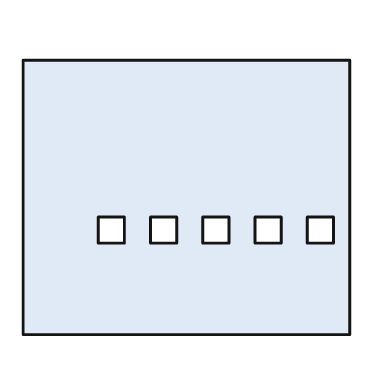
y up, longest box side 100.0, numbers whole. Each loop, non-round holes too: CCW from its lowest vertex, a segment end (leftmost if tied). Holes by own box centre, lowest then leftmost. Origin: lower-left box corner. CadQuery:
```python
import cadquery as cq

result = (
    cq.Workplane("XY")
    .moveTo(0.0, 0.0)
    .lineTo(100.0, 0.0)
    .lineTo(100.0, 84.0)
    .lineTo(0.0, 84.0)
    .close()
    .moveTo(23.0, 28.0)
    .lineTo(31.0, 28.0)
    .lineTo(31.0, 36.0)
    .lineTo(23.0, 36.0)
    .close()
    .moveTo(39.0, 28.0)
    .lineTo(47.0, 28.0)
    .lineTo(47.0, 36.0)
    .lineTo(39.0, 36.0)
    .close()
    .moveTo(55.0, 28.0)
    .lineTo(63.0, 28.0)
    .lineTo(63.0, 36.0)
    .lineTo(55.0, 36.0)
    .close()
    .moveTo(71.0, 28.0)
    .lineTo(79.0, 28.0)
    .lineTo(79.0, 36.0)
    .lineTo(71.0, 36.0)
    .close()
    .moveTo(87.0, 28.0)
    .lineTo(95.0, 28.0)
    .lineTo(95.0, 36.0)
    .lineTo(87.0, 36.0)
    .close()
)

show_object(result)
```